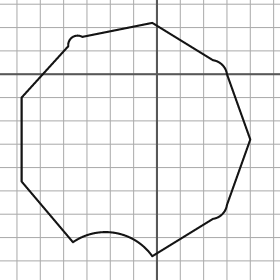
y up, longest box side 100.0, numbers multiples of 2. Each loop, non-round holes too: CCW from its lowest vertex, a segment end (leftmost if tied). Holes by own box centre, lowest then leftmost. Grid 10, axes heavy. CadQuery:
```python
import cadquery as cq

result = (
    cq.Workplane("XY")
    .moveTo(-2.0, -78.0)
    .lineTo(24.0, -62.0)
    .threePointArc((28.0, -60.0), (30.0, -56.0))
    .lineTo(40.0, -28.0)
    .lineTo(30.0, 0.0)
    .threePointArc((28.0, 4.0), (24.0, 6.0))
    .lineTo(-2.0, 22.0)
    .lineTo(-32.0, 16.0)
    .threePointArc((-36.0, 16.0), (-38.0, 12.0))
    .lineTo(-58.0, -10.0)
    .lineTo(-58.0, -46.0)
    .lineTo(-36.0, -72.0)
    .threePointArc((-18.0, -68.0), (-2.0, -78.0))
    .close()
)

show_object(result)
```